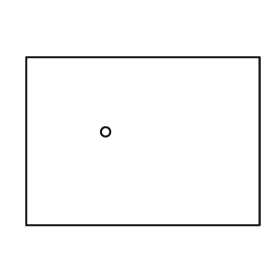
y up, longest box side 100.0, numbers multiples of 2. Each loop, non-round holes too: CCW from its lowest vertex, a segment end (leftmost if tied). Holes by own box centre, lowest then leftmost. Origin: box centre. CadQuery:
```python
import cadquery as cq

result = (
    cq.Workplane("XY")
    .moveTo(-50.0, -36.0)
    .lineTo(50.0, -36.0)
    .lineTo(50.0, 36.0)
    .lineTo(-50.0, 36.0)
    .close()
    .moveTo(-16.0, 4.0)
    .circle(2.0)
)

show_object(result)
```